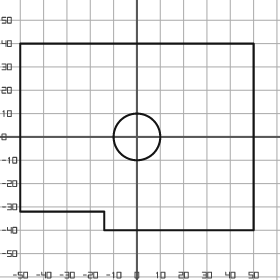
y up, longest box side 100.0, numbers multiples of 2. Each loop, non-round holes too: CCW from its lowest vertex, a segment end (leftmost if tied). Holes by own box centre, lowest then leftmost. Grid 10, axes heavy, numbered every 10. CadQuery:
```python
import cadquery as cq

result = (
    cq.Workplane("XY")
    .moveTo(-14.0, -40.0)
    .lineTo(50.0, -40.0)
    .lineTo(50.0, 40.0)
    .lineTo(-50.0, 40.0)
    .lineTo(-50.0, -32.0)
    .lineTo(-14.0, -32.0)
    .close()
    .moveTo(0.0, 0.0)
    .circle(10.0)
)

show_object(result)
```